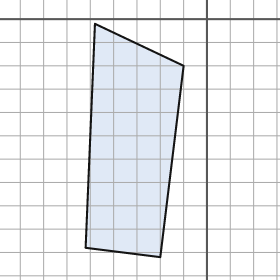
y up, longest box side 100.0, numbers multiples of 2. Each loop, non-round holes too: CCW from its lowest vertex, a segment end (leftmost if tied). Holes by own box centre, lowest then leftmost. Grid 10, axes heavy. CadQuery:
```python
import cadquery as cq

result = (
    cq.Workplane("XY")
    .moveTo(-20.0, -102.0)
    .lineTo(-10.0, -20.0)
    .lineTo(-48.0, -2.0)
    .lineTo(-52.0, -98.0)
    .close()
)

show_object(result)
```